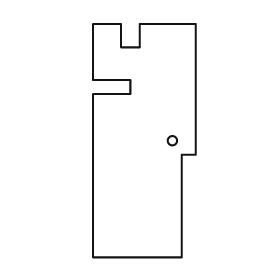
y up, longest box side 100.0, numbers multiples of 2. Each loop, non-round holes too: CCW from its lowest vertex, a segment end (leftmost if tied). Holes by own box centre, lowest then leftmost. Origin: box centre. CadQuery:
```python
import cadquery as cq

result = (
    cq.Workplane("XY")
    .moveTo(-22.0, -50.0)
    .lineTo(16.0, -50.0)
    .lineTo(16.0, -6.0)
    .lineTo(22.0, -6.0)
    .lineTo(22.0, 50.0)
    .lineTo(-2.0, 50.0)
    .lineTo(-2.0, 40.0)
    .lineTo(-10.0, 40.0)
    .lineTo(-10.0, 50.0)
    .lineTo(-22.0, 50.0)
    .lineTo(-22.0, 26.0)
    .lineTo(-6.0, 26.0)
    .lineTo(-6.0, 20.0)
    .lineTo(-22.0, 20.0)
    .close()
    .moveTo(12.0, 0.0)
    .circle(2.0)
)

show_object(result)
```